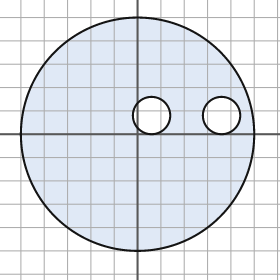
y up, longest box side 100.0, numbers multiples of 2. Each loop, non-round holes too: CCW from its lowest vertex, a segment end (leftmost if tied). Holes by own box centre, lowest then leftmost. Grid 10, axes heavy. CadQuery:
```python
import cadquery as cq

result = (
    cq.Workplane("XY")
    .moveTo(0.0, 0.0)
    .circle(50.0)
    .moveTo(6.0, 8.0)
    .circle(8.0)
    .moveTo(36.0, 8.0)
    .circle(8.0)
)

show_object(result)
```